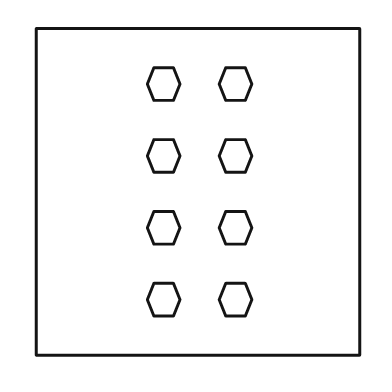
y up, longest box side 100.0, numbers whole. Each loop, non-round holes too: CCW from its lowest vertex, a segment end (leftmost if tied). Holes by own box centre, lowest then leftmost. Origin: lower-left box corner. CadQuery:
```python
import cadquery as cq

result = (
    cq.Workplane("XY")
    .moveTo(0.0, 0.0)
    .lineTo(99.0, 0.0)
    .lineTo(99.0, 100.0)
    .lineTo(0.0, 100.0)
    .close()
    .moveTo(36.0, 12.0)
    .lineTo(42.0, 12.0)
    .lineTo(44.0, 17.0)
    .lineTo(42.0, 22.0)
    .lineTo(36.0, 22.0)
    .lineTo(34.0, 17.0)
    .close()
    .moveTo(58.0, 12.0)
    .lineTo(64.0, 12.0)
    .lineTo(66.0, 17.0)
    .lineTo(64.0, 22.0)
    .lineTo(58.0, 22.0)
    .lineTo(56.0, 17.0)
    .close()
    .moveTo(36.0, 34.0)
    .lineTo(42.0, 34.0)
    .lineTo(44.0, 39.0)
    .lineTo(42.0, 44.0)
    .lineTo(36.0, 44.0)
    .lineTo(34.0, 39.0)
    .close()
    .moveTo(58.0, 34.0)
    .lineTo(64.0, 34.0)
    .lineTo(66.0, 39.0)
    .lineTo(64.0, 44.0)
    .lineTo(58.0, 44.0)
    .lineTo(56.0, 39.0)
    .close()
    .moveTo(36.0, 56.0)
    .lineTo(42.0, 56.0)
    .lineTo(44.0, 61.0)
    .lineTo(42.0, 66.0)
    .lineTo(36.0, 66.0)
    .lineTo(34.0, 61.0)
    .close()
    .moveTo(58.0, 56.0)
    .lineTo(64.0, 56.0)
    .lineTo(66.0, 61.0)
    .lineTo(64.0, 66.0)
    .lineTo(58.0, 66.0)
    .lineTo(56.0, 61.0)
    .close()
    .moveTo(36.0, 78.0)
    .lineTo(42.0, 78.0)
    .lineTo(44.0, 83.0)
    .lineTo(42.0, 88.0)
    .lineTo(36.0, 88.0)
    .lineTo(34.0, 83.0)
    .close()
    .moveTo(58.0, 78.0)
    .lineTo(64.0, 78.0)
    .lineTo(66.0, 83.0)
    .lineTo(64.0, 88.0)
    .lineTo(58.0, 88.0)
    .lineTo(56.0, 83.0)
    .close()
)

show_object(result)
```